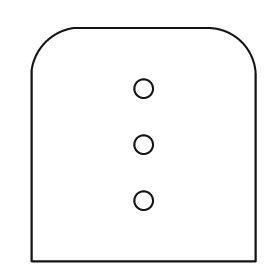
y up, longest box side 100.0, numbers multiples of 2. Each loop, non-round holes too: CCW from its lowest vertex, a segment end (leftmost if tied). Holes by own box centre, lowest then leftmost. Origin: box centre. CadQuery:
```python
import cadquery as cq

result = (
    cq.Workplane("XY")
    .moveTo(-48.0, -50.0)
    .lineTo(48.0, -50.0)
    .lineTo(48.0, 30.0)
    .threePointArc((42.0, 44.0), (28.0, 50.0))
    .lineTo(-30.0, 50.0)
    .threePointArc((-42.0, 44.0), (-48.0, 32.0))
    .close()
    .moveTo(0.0, -24.0)
    .circle(4.0)
    .moveTo(0.0, 0.0)
    .circle(4.0)
    .moveTo(0.0, 24.0)
    .circle(4.0)
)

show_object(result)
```